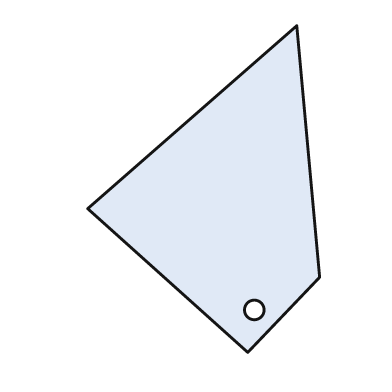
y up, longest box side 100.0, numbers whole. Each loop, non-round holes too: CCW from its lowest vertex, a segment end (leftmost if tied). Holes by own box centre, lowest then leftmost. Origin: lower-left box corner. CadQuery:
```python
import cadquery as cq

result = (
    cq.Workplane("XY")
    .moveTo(49.0, 0.0)
    .lineTo(71.0, 23.0)
    .lineTo(64.0, 100.0)
    .lineTo(0.0, 44.0)
    .close()
    .moveTo(51.0, 13.0)
    .circle(3.0)
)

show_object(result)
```